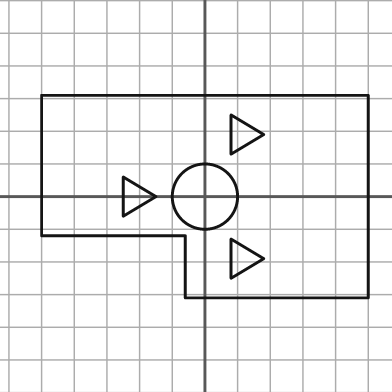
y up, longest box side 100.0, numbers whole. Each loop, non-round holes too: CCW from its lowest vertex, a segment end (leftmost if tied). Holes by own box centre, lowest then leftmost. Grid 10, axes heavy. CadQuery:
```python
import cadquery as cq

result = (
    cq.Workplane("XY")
    .moveTo(-6.0, -31.0)
    .lineTo(50.0, -31.0)
    .lineTo(50.0, 31.0)
    .lineTo(-50.0, 31.0)
    .lineTo(-50.0, -12.0)
    .lineTo(-6.0, -12.0)
    .close()
    .moveTo(8.0, -25.0)
    .lineTo(18.0, -19.0)
    .lineTo(8.0, -13.0)
    .close()
    .moveTo(-25.0, -6.0)
    .lineTo(-15.0, 0.0)
    .lineTo(-25.0, 6.0)
    .close()
    .moveTo(0.0, 0.0)
    .circle(10.0)
    .moveTo(8.0, 13.0)
    .lineTo(18.0, 19.0)
    .lineTo(8.0, 25.0)
    .close()
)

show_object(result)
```